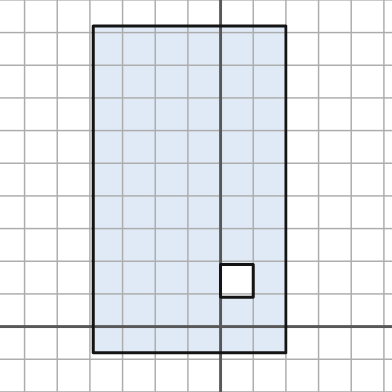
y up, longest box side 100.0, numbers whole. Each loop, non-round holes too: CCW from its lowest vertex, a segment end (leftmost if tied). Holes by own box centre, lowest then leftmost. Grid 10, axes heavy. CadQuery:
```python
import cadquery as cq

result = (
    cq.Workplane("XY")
    .moveTo(-39.0, -8.0)
    .lineTo(20.0, -8.0)
    .lineTo(20.0, 92.0)
    .lineTo(-39.0, 92.0)
    .close()
    .moveTo(0.0, 9.0)
    .lineTo(10.0, 9.0)
    .lineTo(10.0, 19.0)
    .lineTo(0.0, 19.0)
    .close()
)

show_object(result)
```